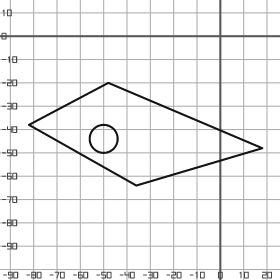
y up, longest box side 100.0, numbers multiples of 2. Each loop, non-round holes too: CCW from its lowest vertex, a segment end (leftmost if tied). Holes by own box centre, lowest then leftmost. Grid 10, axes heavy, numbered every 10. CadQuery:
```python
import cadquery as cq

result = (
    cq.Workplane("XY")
    .moveTo(-36.0, -64.0)
    .lineTo(18.0, -48.0)
    .lineTo(-48.0, -20.0)
    .lineTo(-82.0, -38.0)
    .close()
    .moveTo(-50.0, -44.0)
    .circle(6.0)
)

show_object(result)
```